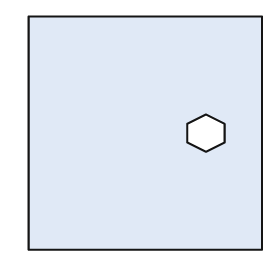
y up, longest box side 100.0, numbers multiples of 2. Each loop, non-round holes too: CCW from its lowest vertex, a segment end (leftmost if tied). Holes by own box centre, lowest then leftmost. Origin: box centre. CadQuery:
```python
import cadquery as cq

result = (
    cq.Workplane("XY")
    .moveTo(-50.0, -50.0)
    .lineTo(50.0, -50.0)
    .lineTo(50.0, 50.0)
    .lineTo(-50.0, 50.0)
    .close()
    .moveTo(26.0, -8.0)
    .lineTo(34.0, -4.0)
    .lineTo(34.0, 4.0)
    .lineTo(26.0, 8.0)
    .lineTo(18.0, 4.0)
    .lineTo(18.0, -4.0)
    .close()
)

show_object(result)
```